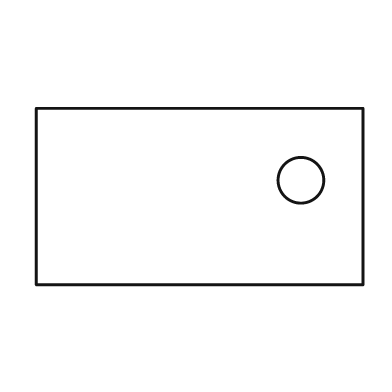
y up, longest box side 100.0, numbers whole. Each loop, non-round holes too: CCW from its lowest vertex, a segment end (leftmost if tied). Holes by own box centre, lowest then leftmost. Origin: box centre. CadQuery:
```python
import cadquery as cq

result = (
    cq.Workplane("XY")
    .moveTo(-50.0, -27.0)
    .lineTo(50.0, -27.0)
    .lineTo(50.0, 27.0)
    .lineTo(-50.0, 27.0)
    .close()
    .moveTo(31.0, 5.0)
    .circle(7.0)
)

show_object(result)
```